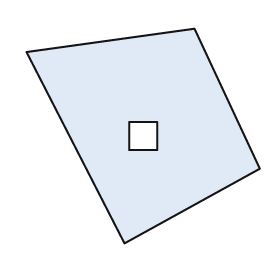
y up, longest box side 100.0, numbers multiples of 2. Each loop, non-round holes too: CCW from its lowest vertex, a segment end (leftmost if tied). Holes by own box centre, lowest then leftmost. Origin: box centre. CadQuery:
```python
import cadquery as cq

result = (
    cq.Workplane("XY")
    .moveTo(-8.0, -46.0)
    .lineTo(50.0, -14.0)
    .lineTo(22.0, 46.0)
    .lineTo(-50.0, 36.0)
    .close()
    .moveTo(-6.0, -6.0)
    .lineTo(6.0, -6.0)
    .lineTo(6.0, 6.0)
    .lineTo(-6.0, 6.0)
    .close()
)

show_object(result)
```